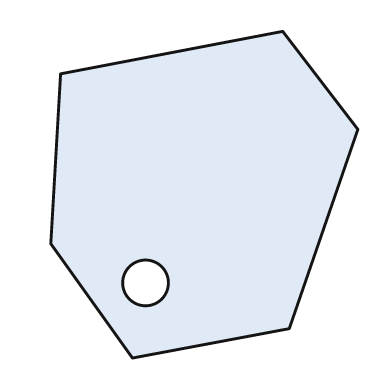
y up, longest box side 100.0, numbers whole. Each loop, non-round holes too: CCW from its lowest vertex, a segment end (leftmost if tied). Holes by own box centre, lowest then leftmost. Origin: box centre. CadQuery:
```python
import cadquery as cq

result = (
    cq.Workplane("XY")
    .moveTo(-22.0, -50.0)
    .lineTo(26.0, -41.0)
    .lineTo(47.0, 20.0)
    .lineTo(24.0, 50.0)
    .lineTo(-44.0, 37.0)
    .lineTo(-47.0, -15.0)
    .close()
    .moveTo(-18.0, -27.0)
    .circle(7.0)
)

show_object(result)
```